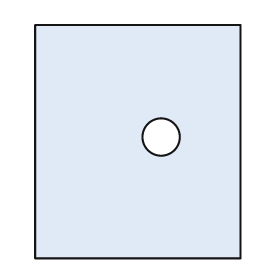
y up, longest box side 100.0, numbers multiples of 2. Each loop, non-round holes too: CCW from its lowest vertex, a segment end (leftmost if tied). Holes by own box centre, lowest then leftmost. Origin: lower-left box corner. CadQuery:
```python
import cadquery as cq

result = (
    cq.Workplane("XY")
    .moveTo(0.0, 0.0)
    .lineTo(88.0, 0.0)
    .lineTo(88.0, 100.0)
    .lineTo(0.0, 100.0)
    .close()
    .moveTo(54.0, 52.0)
    .circle(8.0)
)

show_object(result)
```